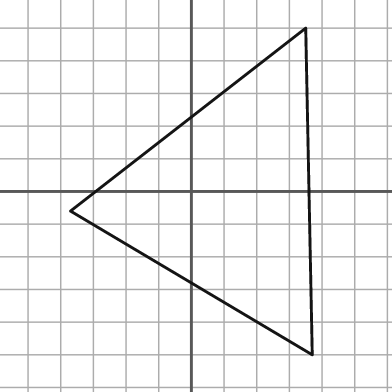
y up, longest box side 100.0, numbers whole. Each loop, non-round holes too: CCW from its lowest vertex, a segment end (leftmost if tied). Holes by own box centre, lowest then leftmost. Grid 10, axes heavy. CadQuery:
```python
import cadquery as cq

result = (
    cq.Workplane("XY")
    .moveTo(37.0, -50.0)
    .lineTo(35.0, 50.0)
    .lineTo(-37.0, -6.0)
    .close()
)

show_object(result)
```